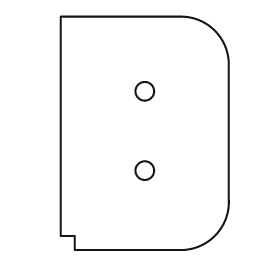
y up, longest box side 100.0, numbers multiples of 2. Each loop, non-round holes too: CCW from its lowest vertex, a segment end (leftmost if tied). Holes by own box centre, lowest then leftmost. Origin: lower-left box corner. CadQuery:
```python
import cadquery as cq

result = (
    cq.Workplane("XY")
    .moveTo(6.0, 0.0)
    .lineTo(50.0, 0.0)
    .threePointArc((66.0, 6.0), (72.0, 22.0))
    .lineTo(72.0, 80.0)
    .threePointArc((66.0, 94.0), (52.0, 100.0))
    .lineTo(0.0, 100.0)
    .lineTo(0.0, 6.0)
    .lineTo(6.0, 6.0)
    .close()
    .moveTo(36.0, 34.0)
    .circle(4.0)
    .moveTo(36.0, 68.0)
    .circle(4.0)
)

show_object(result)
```